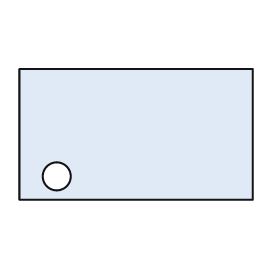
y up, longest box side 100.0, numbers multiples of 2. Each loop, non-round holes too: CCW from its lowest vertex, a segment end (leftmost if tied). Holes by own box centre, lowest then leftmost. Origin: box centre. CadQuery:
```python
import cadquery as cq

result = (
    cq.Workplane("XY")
    .moveTo(-50.0, -28.0)
    .lineTo(50.0, -28.0)
    .lineTo(50.0, 28.0)
    .lineTo(-50.0, 28.0)
    .close()
    .moveTo(-34.0, -18.0)
    .circle(6.0)
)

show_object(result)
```